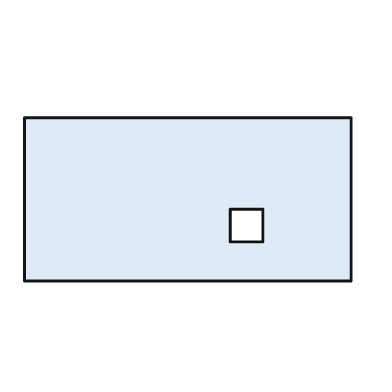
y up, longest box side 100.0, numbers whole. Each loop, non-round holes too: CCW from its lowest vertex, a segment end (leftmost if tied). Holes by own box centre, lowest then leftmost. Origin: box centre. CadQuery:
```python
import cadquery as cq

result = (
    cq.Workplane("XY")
    .moveTo(-50.0, -25.0)
    .lineTo(50.0, -25.0)
    .lineTo(50.0, 25.0)
    .lineTo(-50.0, 25.0)
    .close()
    .moveTo(13.0, -13.0)
    .lineTo(23.0, -13.0)
    .lineTo(23.0, -3.0)
    .lineTo(13.0, -3.0)
    .close()
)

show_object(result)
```